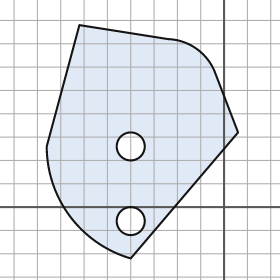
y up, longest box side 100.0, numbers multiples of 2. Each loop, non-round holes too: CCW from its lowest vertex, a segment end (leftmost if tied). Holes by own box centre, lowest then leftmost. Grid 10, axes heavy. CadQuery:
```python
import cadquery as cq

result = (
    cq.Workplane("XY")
    .moveTo(-40.0, -22.0)
    .lineTo(6.0, 32.0)
    .lineTo(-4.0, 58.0)
    .threePointArc((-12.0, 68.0), (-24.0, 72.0))
    .lineTo(-62.0, 78.0)
    .lineTo(-76.0, 26.0)
    .threePointArc((-66.0, -4.0), (-40.0, -22.0))
    .close()
    .moveTo(-40.0, -6.0)
    .circle(6.0)
    .moveTo(-40.0, 26.0)
    .circle(6.0)
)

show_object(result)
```